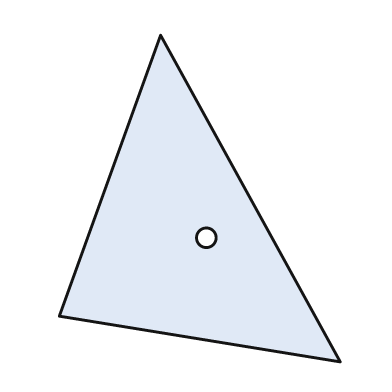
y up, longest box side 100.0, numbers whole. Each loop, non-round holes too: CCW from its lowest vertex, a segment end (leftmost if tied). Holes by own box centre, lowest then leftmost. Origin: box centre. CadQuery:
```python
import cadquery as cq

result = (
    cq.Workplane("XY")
    .moveTo(43.0, -50.0)
    .lineTo(-12.0, 50.0)
    .lineTo(-43.0, -36.0)
    .close()
    .moveTo(2.0, -12.0)
    .circle(3.0)
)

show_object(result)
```